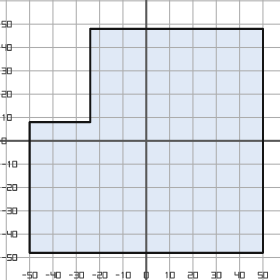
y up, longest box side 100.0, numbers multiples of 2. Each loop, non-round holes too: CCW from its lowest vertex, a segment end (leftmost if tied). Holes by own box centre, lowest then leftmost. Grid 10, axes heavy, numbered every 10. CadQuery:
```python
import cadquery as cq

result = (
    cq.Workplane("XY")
    .moveTo(-50.0, -48.0)
    .lineTo(50.0, -48.0)
    .lineTo(50.0, 48.0)
    .lineTo(-24.0, 48.0)
    .lineTo(-24.0, 8.0)
    .lineTo(-50.0, 8.0)
    .close()
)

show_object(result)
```